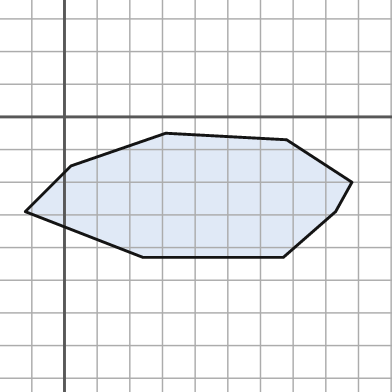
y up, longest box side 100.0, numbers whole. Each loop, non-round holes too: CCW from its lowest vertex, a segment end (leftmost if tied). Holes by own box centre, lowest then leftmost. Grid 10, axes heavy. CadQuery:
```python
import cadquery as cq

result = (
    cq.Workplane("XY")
    .moveTo(24.0, -43.0)
    .lineTo(67.0, -43.0)
    .lineTo(83.0, -29.0)
    .lineTo(88.0, -20.0)
    .lineTo(68.0, -7.0)
    .lineTo(31.0, -5.0)
    .lineTo(2.0, -15.0)
    .lineTo(-12.0, -29.0)
    .close()
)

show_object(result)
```